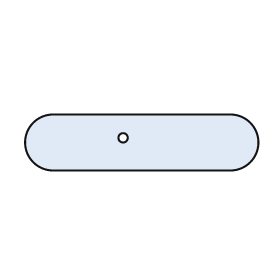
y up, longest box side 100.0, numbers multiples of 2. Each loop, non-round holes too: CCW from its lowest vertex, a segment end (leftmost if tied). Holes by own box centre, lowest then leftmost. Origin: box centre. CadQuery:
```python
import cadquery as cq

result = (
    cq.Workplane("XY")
    .moveTo(-38.0, -12.0)
    .lineTo(38.0, -12.0)
    .threePointArc((50.0, 0.0), (38.0, 12.0))
    .lineTo(-38.0, 12.0)
    .threePointArc((-50.0, 0.0), (-38.0, -12.0))
    .close()
    .moveTo(-8.0, 2.0)
    .circle(2.0)
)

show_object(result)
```